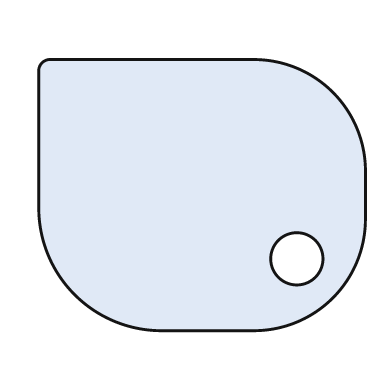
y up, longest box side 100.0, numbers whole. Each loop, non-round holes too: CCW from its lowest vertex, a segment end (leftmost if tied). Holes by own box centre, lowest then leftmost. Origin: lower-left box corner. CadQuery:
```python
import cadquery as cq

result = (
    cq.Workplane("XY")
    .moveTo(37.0, 0.0)
    .lineTo(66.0, 0.0)
    .threePointArc((90.0, 10.0), (100.0, 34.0))
    .lineTo(100.0, 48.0)
    .threePointArc((90.0, 73.0), (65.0, 83.0))
    .lineTo(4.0, 83.0)
    .threePointArc((1.0, 82.0), (0.0, 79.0))
    .lineTo(0.0, 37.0)
    .threePointArc((11.0, 11.0), (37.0, 0.0))
    .close()
    .moveTo(79.0, 22.0)
    .circle(8.0)
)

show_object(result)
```